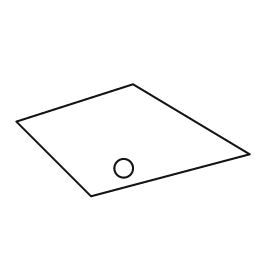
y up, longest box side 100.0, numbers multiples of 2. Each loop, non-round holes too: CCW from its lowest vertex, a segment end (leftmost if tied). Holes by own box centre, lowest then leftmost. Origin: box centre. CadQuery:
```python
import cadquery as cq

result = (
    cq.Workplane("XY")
    .moveTo(-18.0, -24.0)
    .lineTo(50.0, -6.0)
    .lineTo(0.0, 24.0)
    .lineTo(-50.0, 8.0)
    .close()
    .moveTo(-4.0, -12.0)
    .circle(4.0)
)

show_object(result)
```